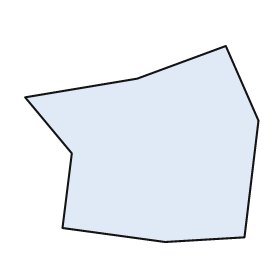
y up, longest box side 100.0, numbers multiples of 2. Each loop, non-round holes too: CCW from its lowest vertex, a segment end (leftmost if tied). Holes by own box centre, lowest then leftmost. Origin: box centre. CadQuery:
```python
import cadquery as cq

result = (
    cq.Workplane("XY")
    .moveTo(10.0, -42.0)
    .lineTo(44.0, -40.0)
    .lineTo(50.0, 10.0)
    .lineTo(36.0, 42.0)
    .lineTo(-2.0, 28.0)
    .lineTo(-50.0, 20.0)
    .lineTo(-30.0, -4.0)
    .lineTo(-34.0, -36.0)
    .close()
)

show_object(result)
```